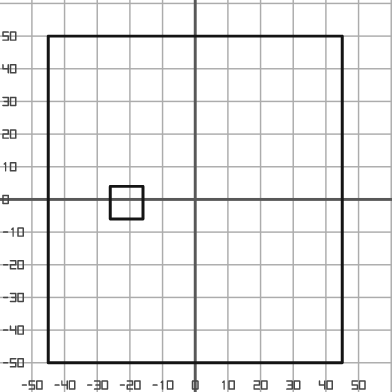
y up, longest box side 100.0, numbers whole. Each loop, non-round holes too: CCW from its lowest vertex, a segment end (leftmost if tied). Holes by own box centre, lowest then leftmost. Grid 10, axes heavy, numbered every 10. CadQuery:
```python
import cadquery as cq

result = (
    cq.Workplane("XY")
    .moveTo(-45.0, -50.0)
    .lineTo(45.0, -50.0)
    .lineTo(45.0, 50.0)
    .lineTo(-45.0, 50.0)
    .close()
    .moveTo(-26.0, -6.0)
    .lineTo(-16.0, -6.0)
    .lineTo(-16.0, 4.0)
    .lineTo(-26.0, 4.0)
    .close()
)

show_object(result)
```